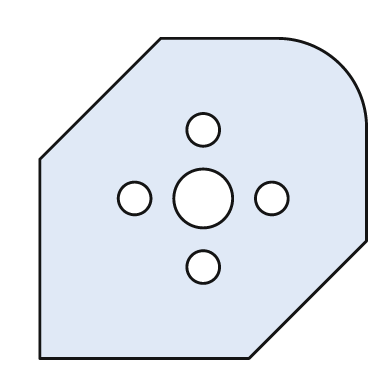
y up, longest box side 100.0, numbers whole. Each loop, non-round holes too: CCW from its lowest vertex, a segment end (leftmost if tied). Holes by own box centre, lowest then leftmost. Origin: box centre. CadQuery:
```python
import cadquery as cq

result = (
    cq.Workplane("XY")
    .moveTo(-50.0, -49.0)
    .lineTo(14.0, -49.0)
    .lineTo(50.0, -13.0)
    .lineTo(50.0, 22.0)
    .threePointArc((42.0, 41.0), (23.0, 49.0))
    .lineTo(-13.0, 49.0)
    .lineTo(-50.0, 12.0)
    .close()
    .moveTo(0.0, -21.0)
    .circle(5.0)
    .moveTo(-21.0, 0.0)
    .circle(5.0)
    .moveTo(0.0, 0.0)
    .circle(9.0)
    .moveTo(21.0, 0.0)
    .circle(5.0)
    .moveTo(0.0, 21.0)
    .circle(5.0)
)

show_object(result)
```